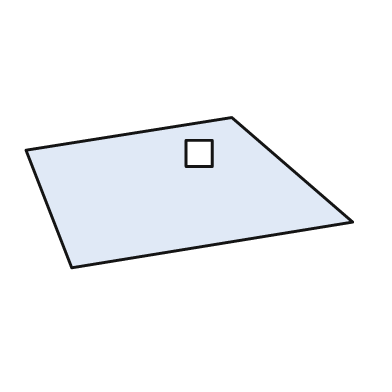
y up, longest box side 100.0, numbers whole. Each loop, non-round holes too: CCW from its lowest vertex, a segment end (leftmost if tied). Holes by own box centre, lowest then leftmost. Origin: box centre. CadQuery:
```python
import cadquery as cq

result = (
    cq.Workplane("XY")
    .moveTo(-36.0, -23.0)
    .lineTo(50.0, -9.0)
    .lineTo(13.0, 23.0)
    .lineTo(-50.0, 13.0)
    .close()
    .moveTo(-1.0, 8.0)
    .lineTo(7.0, 8.0)
    .lineTo(7.0, 16.0)
    .lineTo(-1.0, 16.0)
    .close()
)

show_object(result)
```